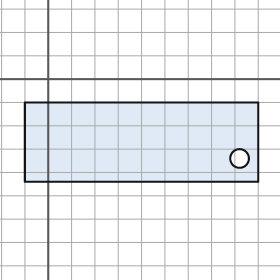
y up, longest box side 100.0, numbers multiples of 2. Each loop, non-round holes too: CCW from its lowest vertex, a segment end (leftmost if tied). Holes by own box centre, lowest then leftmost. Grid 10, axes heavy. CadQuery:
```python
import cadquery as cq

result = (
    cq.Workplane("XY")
    .moveTo(-10.0, -44.0)
    .lineTo(90.0, -44.0)
    .lineTo(90.0, -10.0)
    .lineTo(-10.0, -10.0)
    .close()
    .moveTo(82.0, -34.0)
    .circle(4.0)
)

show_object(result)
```